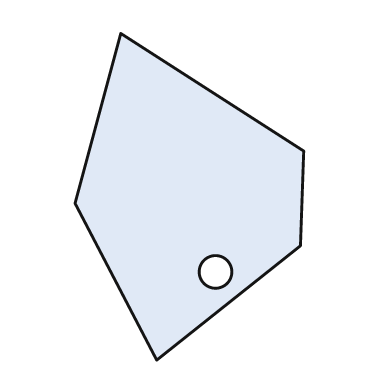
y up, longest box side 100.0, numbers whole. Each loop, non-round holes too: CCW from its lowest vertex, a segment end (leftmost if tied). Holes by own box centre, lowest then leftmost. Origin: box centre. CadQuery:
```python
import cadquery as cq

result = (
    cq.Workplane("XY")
    .moveTo(-10.0, -50.0)
    .lineTo(34.0, -15.0)
    .lineTo(35.0, 14.0)
    .lineTo(-21.0, 50.0)
    .lineTo(-35.0, -2.0)
    .close()
    .moveTo(8.0, -23.0)
    .circle(5.0)
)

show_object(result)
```